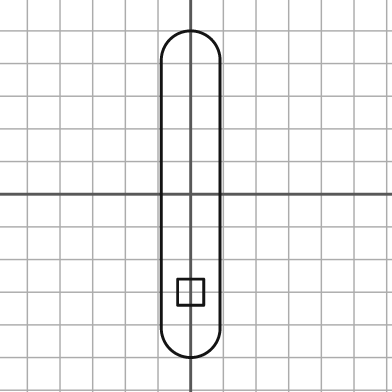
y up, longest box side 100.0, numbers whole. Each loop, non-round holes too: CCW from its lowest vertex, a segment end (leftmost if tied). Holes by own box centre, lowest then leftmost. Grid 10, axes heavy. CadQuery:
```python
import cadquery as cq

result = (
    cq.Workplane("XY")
    .moveTo(-9.0, -41.0)
    .threePointArc((0.0, -50.0), (9.0, -41.0))
    .lineTo(9.0, 41.0)
    .threePointArc((0.0, 50.0), (-9.0, 41.0))
    .close()
    .moveTo(-4.0, -34.0)
    .lineTo(4.0, -34.0)
    .lineTo(4.0, -26.0)
    .lineTo(-4.0, -26.0)
    .close()
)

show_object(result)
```